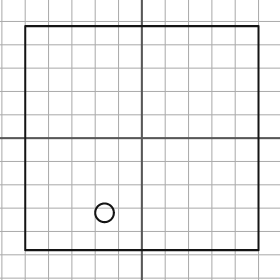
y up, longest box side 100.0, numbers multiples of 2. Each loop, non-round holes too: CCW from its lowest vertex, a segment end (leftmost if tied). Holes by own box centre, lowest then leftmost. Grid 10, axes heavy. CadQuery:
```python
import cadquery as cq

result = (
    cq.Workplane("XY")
    .moveTo(-50.0, -48.0)
    .lineTo(50.0, -48.0)
    .lineTo(50.0, 48.0)
    .lineTo(-50.0, 48.0)
    .close()
    .moveTo(-16.0, -32.0)
    .circle(4.0)
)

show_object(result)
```